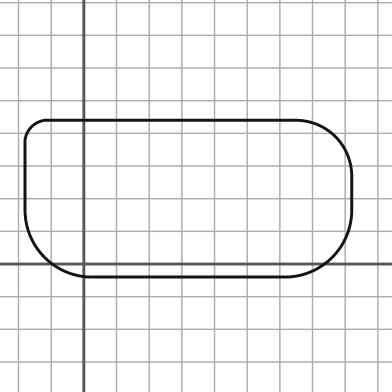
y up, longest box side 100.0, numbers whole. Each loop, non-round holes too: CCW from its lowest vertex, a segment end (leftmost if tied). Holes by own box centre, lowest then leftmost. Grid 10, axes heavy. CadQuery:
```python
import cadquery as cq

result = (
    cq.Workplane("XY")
    .moveTo(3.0, -4.0)
    .lineTo(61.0, -4.0)
    .threePointArc((76.0, 2.0), (82.0, 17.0))
    .lineTo(82.0, 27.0)
    .threePointArc((77.0, 39.0), (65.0, 44.0))
    .lineTo(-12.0, 44.0)
    .threePointArc((-16.0, 42.0), (-18.0, 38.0))
    .lineTo(-18.0, 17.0)
    .threePointArc((-12.0, 2.0), (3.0, -4.0))
    .close()
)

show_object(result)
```